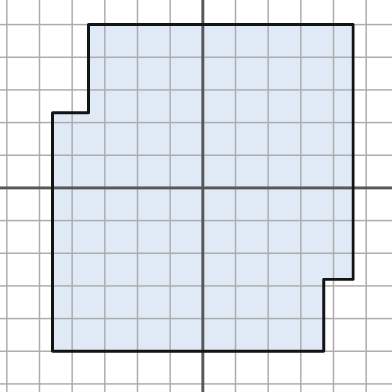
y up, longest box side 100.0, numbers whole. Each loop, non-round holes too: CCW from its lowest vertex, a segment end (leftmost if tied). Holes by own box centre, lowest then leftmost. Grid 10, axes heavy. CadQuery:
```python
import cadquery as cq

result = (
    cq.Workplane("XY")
    .moveTo(-46.0, -50.0)
    .lineTo(37.0, -50.0)
    .lineTo(37.0, -28.0)
    .lineTo(46.0, -28.0)
    .lineTo(46.0, 50.0)
    .lineTo(-35.0, 50.0)
    .lineTo(-35.0, 23.0)
    .lineTo(-46.0, 23.0)
    .close()
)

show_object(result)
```